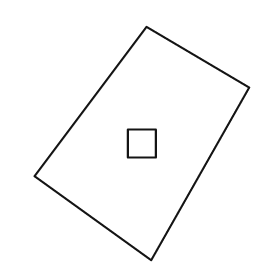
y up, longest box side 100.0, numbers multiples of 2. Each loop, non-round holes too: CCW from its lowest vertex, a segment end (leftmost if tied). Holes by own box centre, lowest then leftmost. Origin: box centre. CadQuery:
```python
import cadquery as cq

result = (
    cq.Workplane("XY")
    .moveTo(4.0, -50.0)
    .lineTo(46.0, 24.0)
    .lineTo(2.0, 50.0)
    .lineTo(-46.0, -14.0)
    .close()
    .moveTo(-6.0, -6.0)
    .lineTo(6.0, -6.0)
    .lineTo(6.0, 6.0)
    .lineTo(-6.0, 6.0)
    .close()
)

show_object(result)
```